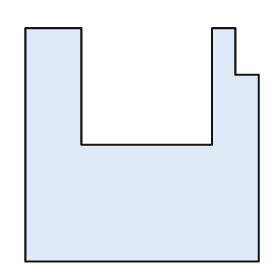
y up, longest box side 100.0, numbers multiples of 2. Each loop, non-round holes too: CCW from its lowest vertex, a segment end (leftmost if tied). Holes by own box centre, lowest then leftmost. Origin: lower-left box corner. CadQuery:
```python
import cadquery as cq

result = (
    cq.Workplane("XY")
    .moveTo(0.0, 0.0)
    .lineTo(100.0, 0.0)
    .lineTo(100.0, 80.0)
    .lineTo(90.0, 80.0)
    .lineTo(90.0, 100.0)
    .lineTo(80.0, 100.0)
    .lineTo(80.0, 50.0)
    .lineTo(24.0, 50.0)
    .lineTo(24.0, 100.0)
    .lineTo(0.0, 100.0)
    .close()
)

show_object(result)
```